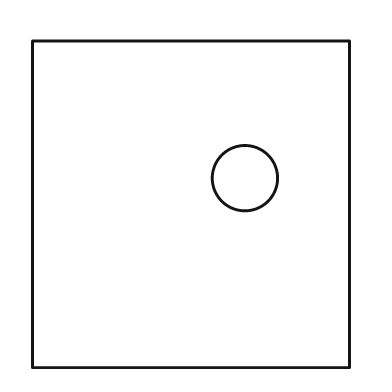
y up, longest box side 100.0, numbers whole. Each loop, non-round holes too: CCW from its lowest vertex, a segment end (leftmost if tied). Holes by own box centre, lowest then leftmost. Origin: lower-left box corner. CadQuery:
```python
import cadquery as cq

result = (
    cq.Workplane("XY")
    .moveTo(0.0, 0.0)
    .lineTo(97.0, 0.0)
    .lineTo(97.0, 100.0)
    .lineTo(0.0, 100.0)
    .close()
    .moveTo(65.0, 58.0)
    .circle(10.0)
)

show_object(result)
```